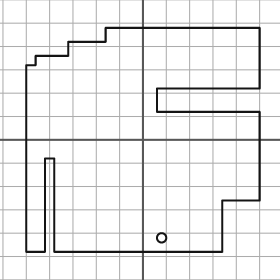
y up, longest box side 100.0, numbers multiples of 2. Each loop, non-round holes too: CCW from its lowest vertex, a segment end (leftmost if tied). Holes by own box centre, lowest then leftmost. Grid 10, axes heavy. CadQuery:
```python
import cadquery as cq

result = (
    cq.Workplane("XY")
    .moveTo(-50.0, -48.0)
    .lineTo(-42.0, -48.0)
    .lineTo(-42.0, -8.0)
    .lineTo(-38.0, -8.0)
    .lineTo(-38.0, -48.0)
    .lineTo(34.0, -48.0)
    .lineTo(34.0, -26.0)
    .lineTo(50.0, -26.0)
    .lineTo(50.0, 12.0)
    .lineTo(6.0, 12.0)
    .lineTo(6.0, 22.0)
    .lineTo(50.0, 22.0)
    .lineTo(50.0, 48.0)
    .lineTo(-16.0, 48.0)
    .lineTo(-16.0, 42.0)
    .lineTo(-32.0, 42.0)
    .lineTo(-32.0, 36.0)
    .lineTo(-46.0, 36.0)
    .lineTo(-46.0, 32.0)
    .lineTo(-50.0, 32.0)
    .close()
    .moveTo(8.0, -42.0)
    .circle(2.0)
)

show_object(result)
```